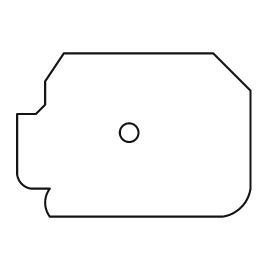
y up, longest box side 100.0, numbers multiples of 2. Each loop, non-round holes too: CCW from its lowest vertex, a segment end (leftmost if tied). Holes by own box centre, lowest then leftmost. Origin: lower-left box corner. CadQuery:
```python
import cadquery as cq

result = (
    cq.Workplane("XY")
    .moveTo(14.0, 0.0)
    .lineTo(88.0, 0.0)
    .threePointArc((96.0, 4.0), (100.0, 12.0))
    .lineTo(100.0, 54.0)
    .lineTo(84.0, 70.0)
    .lineTo(20.0, 70.0)
    .lineTo(12.0, 58.0)
    .lineTo(12.0, 48.0)
    .lineTo(8.0, 44.0)
    .lineTo(0.0, 44.0)
    .lineTo(0.0, 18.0)
    .threePointArc((2.0, 14.0), (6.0, 12.0))
    .lineTo(14.0, 12.0)
    .threePointArc((12.0, 6.0), (14.0, 0.0))
    .close()
    .moveTo(48.0, 36.0)
    .circle(4.0)
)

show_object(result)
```